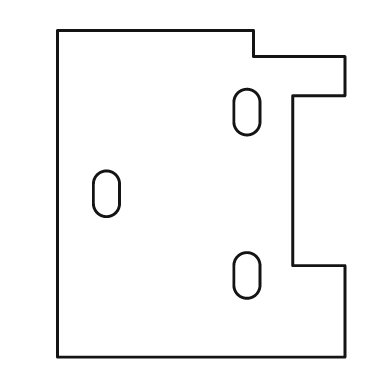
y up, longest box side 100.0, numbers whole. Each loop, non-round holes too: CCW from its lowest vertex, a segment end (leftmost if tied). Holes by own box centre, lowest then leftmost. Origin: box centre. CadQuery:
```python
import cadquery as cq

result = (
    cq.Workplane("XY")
    .moveTo(-44.0, -50.0)
    .lineTo(44.0, -50.0)
    .lineTo(44.0, -22.0)
    .lineTo(28.0, -22.0)
    .lineTo(28.0, 30.0)
    .lineTo(44.0, 30.0)
    .lineTo(44.0, 42.0)
    .lineTo(16.0, 42.0)
    .lineTo(16.0, 50.0)
    .lineTo(-44.0, 50.0)
    .close()
    .moveTo(10.0, -28.0)
    .threePointArc((14.0, -32.0), (18.0, -28.0))
    .lineTo(18.0, -22.0)
    .threePointArc((14.0, -18.0), (10.0, -22.0))
    .close()
    .moveTo(-33.0, -3.0)
    .threePointArc((-29.0, -7.0), (-25.0, -3.0))
    .lineTo(-25.0, 3.0)
    .threePointArc((-29.0, 7.0), (-33.0, 3.0))
    .close()
    .moveTo(10.0, 22.0)
    .threePointArc((14.0, 18.0), (18.0, 22.0))
    .lineTo(18.0, 28.0)
    .threePointArc((14.0, 32.0), (10.0, 28.0))
    .close()
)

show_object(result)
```